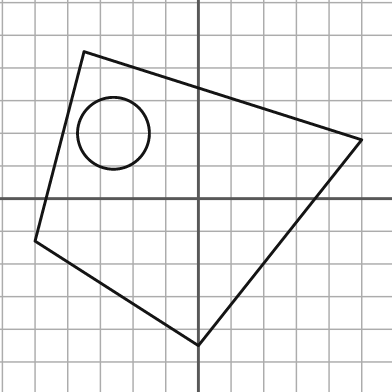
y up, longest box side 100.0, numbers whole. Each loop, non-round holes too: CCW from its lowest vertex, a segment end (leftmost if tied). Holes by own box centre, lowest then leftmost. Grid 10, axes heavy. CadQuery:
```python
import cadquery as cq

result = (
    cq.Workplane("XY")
    .moveTo(0.0, -45.0)
    .lineTo(50.0, 18.0)
    .lineTo(-35.0, 45.0)
    .lineTo(-50.0, -13.0)
    .close()
    .moveTo(-26.0, 20.0)
    .circle(11.0)
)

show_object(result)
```